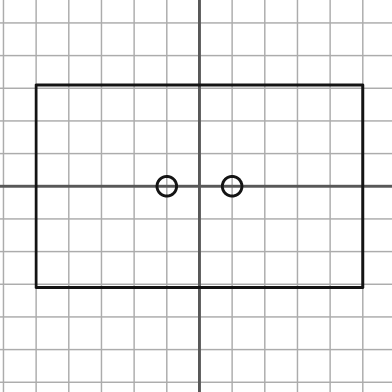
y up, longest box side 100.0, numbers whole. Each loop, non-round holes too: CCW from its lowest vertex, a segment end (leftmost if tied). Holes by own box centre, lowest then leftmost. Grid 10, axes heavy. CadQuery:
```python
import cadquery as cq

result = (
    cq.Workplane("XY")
    .moveTo(-50.0, -31.0)
    .lineTo(50.0, -31.0)
    .lineTo(50.0, 31.0)
    .lineTo(-50.0, 31.0)
    .close()
    .moveTo(-10.0, 0.0)
    .circle(3.0)
    .moveTo(10.0, 0.0)
    .circle(3.0)
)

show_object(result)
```